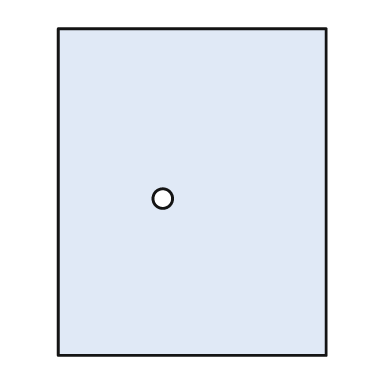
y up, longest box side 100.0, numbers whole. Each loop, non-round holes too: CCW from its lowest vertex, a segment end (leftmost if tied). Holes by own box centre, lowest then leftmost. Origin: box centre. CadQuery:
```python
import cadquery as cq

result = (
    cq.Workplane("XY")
    .moveTo(-41.0, -50.0)
    .lineTo(41.0, -50.0)
    .lineTo(41.0, 50.0)
    .lineTo(-41.0, 50.0)
    .close()
    .moveTo(-9.0, -2.0)
    .circle(3.0)
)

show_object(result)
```